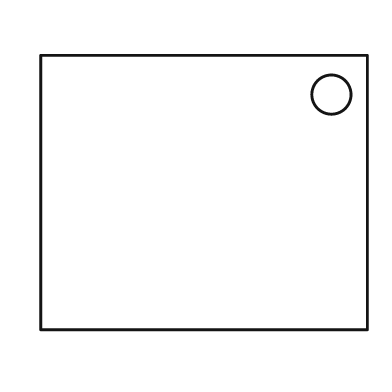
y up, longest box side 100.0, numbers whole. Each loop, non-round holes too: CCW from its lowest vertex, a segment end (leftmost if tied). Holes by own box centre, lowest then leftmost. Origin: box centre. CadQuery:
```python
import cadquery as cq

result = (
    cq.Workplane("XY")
    .moveTo(-50.0, -42.0)
    .lineTo(50.0, -42.0)
    .lineTo(50.0, 42.0)
    .lineTo(-50.0, 42.0)
    .close()
    .moveTo(39.0, 30.0)
    .circle(6.0)
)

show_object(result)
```